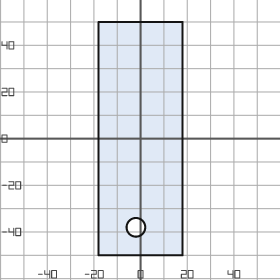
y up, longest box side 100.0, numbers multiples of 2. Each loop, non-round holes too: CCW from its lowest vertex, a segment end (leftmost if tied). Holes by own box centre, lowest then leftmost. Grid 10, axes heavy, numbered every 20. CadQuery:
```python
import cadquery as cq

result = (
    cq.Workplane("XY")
    .moveTo(-18.0, -50.0)
    .lineTo(18.0, -50.0)
    .lineTo(18.0, 50.0)
    .lineTo(-18.0, 50.0)
    .close()
    .moveTo(-2.0, -38.0)
    .circle(4.0)
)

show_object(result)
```